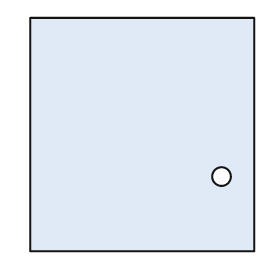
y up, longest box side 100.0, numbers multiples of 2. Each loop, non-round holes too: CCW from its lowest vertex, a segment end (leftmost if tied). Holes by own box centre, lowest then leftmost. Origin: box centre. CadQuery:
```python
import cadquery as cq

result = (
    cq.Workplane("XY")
    .moveTo(-48.0, -50.0)
    .lineTo(48.0, -50.0)
    .lineTo(48.0, 50.0)
    .lineTo(-48.0, 50.0)
    .close()
    .moveTo(34.0, -18.0)
    .circle(4.0)
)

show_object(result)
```